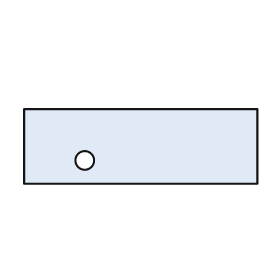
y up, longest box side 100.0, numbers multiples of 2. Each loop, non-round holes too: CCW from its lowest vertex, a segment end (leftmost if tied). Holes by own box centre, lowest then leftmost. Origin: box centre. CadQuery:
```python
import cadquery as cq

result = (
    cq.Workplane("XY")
    .moveTo(-50.0, -16.0)
    .lineTo(50.0, -16.0)
    .lineTo(50.0, 16.0)
    .lineTo(-50.0, 16.0)
    .close()
    .moveTo(-24.0, -6.0)
    .circle(4.0)
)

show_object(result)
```